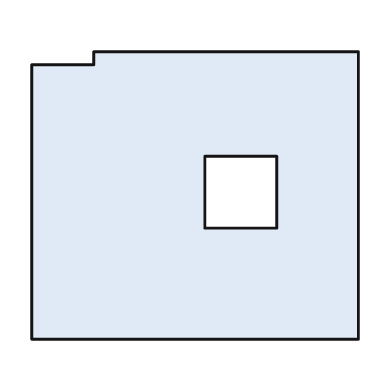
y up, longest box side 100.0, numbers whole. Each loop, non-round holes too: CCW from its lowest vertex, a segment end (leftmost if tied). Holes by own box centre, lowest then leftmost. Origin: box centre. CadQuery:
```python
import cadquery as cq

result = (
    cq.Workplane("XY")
    .moveTo(-50.0, -44.0)
    .lineTo(50.0, -44.0)
    .lineTo(50.0, 44.0)
    .lineTo(-31.0, 44.0)
    .lineTo(-31.0, 40.0)
    .lineTo(-50.0, 40.0)
    .close()
    .moveTo(3.0, -10.0)
    .lineTo(25.0, -10.0)
    .lineTo(25.0, 12.0)
    .lineTo(3.0, 12.0)
    .close()
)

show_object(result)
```